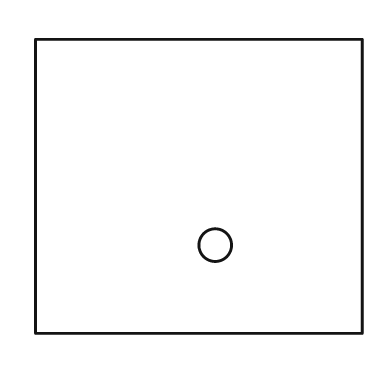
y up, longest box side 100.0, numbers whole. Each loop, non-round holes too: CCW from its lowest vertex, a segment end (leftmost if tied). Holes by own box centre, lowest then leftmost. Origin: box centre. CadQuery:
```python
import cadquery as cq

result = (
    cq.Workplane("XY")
    .moveTo(-50.0, -45.0)
    .lineTo(50.0, -45.0)
    .lineTo(50.0, 45.0)
    .lineTo(-50.0, 45.0)
    .close()
    .moveTo(5.0, -18.0)
    .circle(5.0)
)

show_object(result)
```